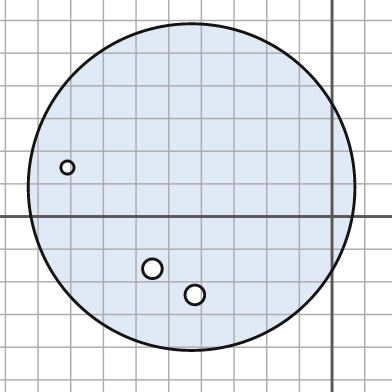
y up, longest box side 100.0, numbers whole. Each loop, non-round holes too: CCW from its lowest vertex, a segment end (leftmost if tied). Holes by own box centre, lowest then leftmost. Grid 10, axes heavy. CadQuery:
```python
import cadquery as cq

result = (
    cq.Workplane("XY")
    .moveTo(-43.0, 9.0)
    .circle(50.0)
    .moveTo(-42.0, -24.0)
    .circle(3.0)
    .moveTo(-55.0, -16.0)
    .circle(3.0)
    .moveTo(-81.0, 15.0)
    .circle(2.0)
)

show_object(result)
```